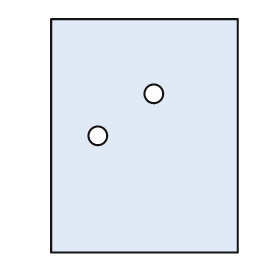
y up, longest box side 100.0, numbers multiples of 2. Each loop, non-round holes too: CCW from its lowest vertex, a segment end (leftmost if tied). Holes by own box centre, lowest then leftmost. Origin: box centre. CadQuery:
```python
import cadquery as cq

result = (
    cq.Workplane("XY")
    .moveTo(-40.0, -50.0)
    .lineTo(40.0, -50.0)
    .lineTo(40.0, 50.0)
    .lineTo(-40.0, 50.0)
    .close()
    .moveTo(-20.0, 0.0)
    .circle(4.0)
    .moveTo(4.0, 18.0)
    .circle(4.0)
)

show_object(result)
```